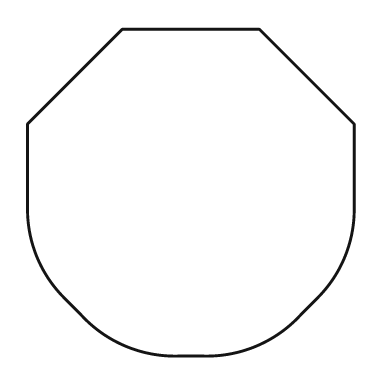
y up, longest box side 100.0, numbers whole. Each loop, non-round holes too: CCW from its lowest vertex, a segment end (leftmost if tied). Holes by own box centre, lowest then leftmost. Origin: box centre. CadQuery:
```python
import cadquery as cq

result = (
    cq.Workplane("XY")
    .moveTo(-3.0, -50.0)
    .lineTo(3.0, -50.0)
    .threePointArc((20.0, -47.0), (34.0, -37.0))
    .lineTo(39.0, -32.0)
    .threePointArc((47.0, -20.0), (50.0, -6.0))
    .lineTo(50.0, 21.0)
    .lineTo(21.0, 50.0)
    .lineTo(-21.0, 50.0)
    .lineTo(-50.0, 21.0)
    .lineTo(-50.0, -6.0)
    .threePointArc((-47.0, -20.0), (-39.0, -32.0))
    .lineTo(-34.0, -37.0)
    .threePointArc((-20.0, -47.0), (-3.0, -50.0))
    .close()
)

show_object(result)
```